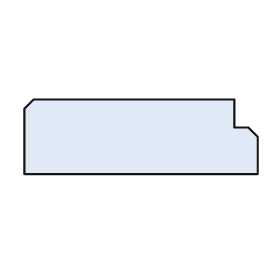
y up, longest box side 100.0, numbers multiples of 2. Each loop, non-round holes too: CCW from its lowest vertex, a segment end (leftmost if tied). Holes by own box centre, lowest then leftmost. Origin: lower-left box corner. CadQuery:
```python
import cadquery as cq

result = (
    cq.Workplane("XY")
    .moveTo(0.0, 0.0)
    .lineTo(100.0, 0.0)
    .lineTo(100.0, 16.0)
    .lineTo(96.0, 20.0)
    .lineTo(90.0, 20.0)
    .lineTo(90.0, 32.0)
    .lineTo(4.0, 32.0)
    .lineTo(0.0, 28.0)
    .close()
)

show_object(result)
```